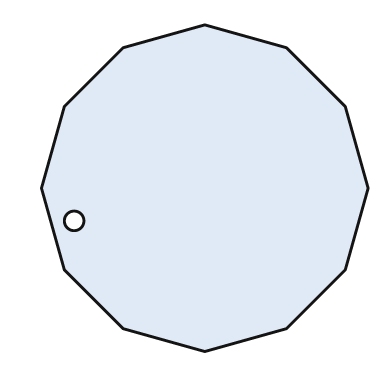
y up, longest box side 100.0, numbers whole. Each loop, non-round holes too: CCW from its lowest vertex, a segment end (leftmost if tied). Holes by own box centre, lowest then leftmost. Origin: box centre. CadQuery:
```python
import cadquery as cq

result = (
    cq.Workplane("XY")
    .moveTo(0.0, -50.0)
    .lineTo(25.0, -43.0)
    .lineTo(43.0, -25.0)
    .lineTo(50.0, 0.0)
    .lineTo(43.0, 25.0)
    .lineTo(25.0, 43.0)
    .lineTo(0.0, 50.0)
    .lineTo(-25.0, 43.0)
    .lineTo(-43.0, 25.0)
    .lineTo(-50.0, 0.0)
    .lineTo(-43.0, -25.0)
    .lineTo(-25.0, -43.0)
    .close()
    .moveTo(-40.0, -10.0)
    .circle(3.0)
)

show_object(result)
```